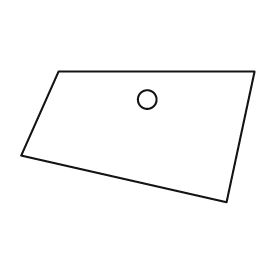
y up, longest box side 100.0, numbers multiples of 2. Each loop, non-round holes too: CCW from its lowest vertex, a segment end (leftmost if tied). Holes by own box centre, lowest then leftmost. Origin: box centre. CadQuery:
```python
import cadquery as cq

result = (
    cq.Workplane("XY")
    .moveTo(38.0, -28.0)
    .lineTo(50.0, 28.0)
    .lineTo(-34.0, 28.0)
    .lineTo(-50.0, -8.0)
    .close()
    .moveTo(4.0, 16.0)
    .circle(4.0)
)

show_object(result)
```